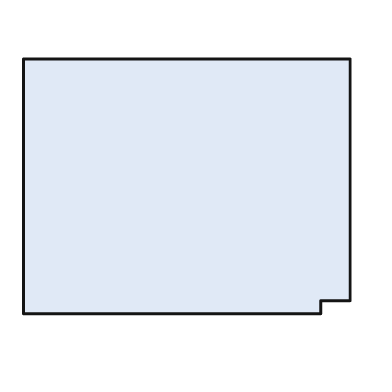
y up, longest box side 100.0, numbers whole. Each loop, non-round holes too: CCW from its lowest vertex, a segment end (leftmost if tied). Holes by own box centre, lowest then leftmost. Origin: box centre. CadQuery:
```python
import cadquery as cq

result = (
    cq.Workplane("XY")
    .moveTo(-50.0, -39.0)
    .lineTo(41.0, -39.0)
    .lineTo(41.0, -35.0)
    .lineTo(50.0, -35.0)
    .lineTo(50.0, 39.0)
    .lineTo(-50.0, 39.0)
    .close()
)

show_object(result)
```